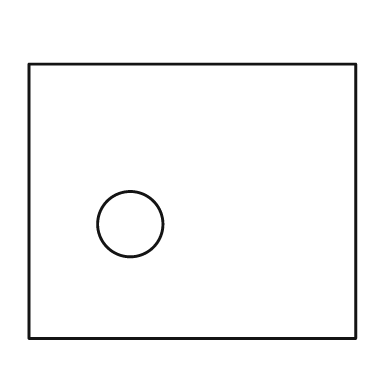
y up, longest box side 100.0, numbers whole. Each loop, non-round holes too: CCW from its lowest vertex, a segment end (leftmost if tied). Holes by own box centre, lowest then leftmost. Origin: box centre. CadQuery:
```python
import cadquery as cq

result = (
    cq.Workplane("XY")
    .moveTo(-50.0, -42.0)
    .lineTo(50.0, -42.0)
    .lineTo(50.0, 42.0)
    .lineTo(-50.0, 42.0)
    .close()
    .moveTo(-19.0, -7.0)
    .circle(10.0)
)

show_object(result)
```